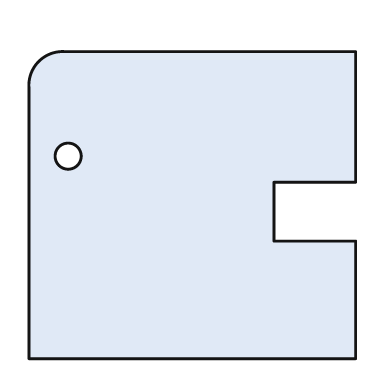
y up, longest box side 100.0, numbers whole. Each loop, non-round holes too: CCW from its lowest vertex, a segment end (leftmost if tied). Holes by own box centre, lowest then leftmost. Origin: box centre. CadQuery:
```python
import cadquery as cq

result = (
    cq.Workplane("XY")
    .moveTo(-50.0, -47.0)
    .lineTo(50.0, -47.0)
    .lineTo(50.0, -11.0)
    .lineTo(25.0, -11.0)
    .lineTo(25.0, 7.0)
    .lineTo(50.0, 7.0)
    .lineTo(50.0, 47.0)
    .lineTo(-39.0, 47.0)
    .threePointArc((-47.0, 44.0), (-50.0, 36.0))
    .close()
    .moveTo(-38.0, 15.0)
    .circle(4.0)
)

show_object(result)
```